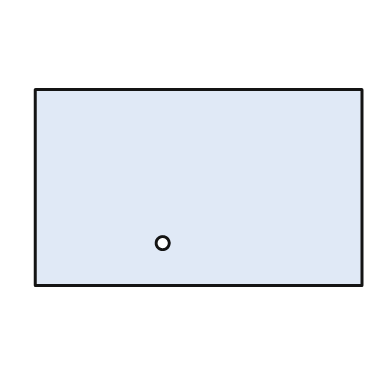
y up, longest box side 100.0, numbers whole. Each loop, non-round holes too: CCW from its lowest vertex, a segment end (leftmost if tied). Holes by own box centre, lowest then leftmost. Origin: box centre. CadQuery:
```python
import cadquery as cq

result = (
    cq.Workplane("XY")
    .moveTo(-50.0, -30.0)
    .lineTo(50.0, -30.0)
    .lineTo(50.0, 30.0)
    .lineTo(-50.0, 30.0)
    .close()
    .moveTo(-11.0, -17.0)
    .circle(2.0)
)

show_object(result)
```